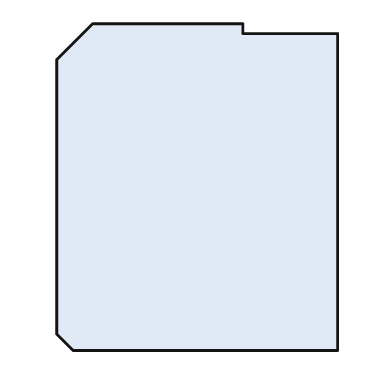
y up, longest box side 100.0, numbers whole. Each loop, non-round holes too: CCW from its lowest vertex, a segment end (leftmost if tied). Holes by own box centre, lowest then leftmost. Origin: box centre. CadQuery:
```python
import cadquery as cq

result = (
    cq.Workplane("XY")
    .moveTo(-38.0, -50.0)
    .lineTo(43.0, -50.0)
    .lineTo(43.0, 47.0)
    .lineTo(14.0, 47.0)
    .lineTo(14.0, 50.0)
    .lineTo(-32.0, 50.0)
    .lineTo(-43.0, 39.0)
    .lineTo(-43.0, -45.0)
    .close()
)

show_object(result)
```